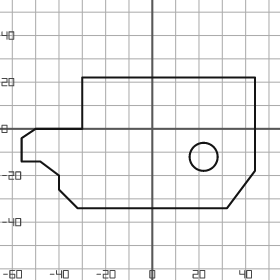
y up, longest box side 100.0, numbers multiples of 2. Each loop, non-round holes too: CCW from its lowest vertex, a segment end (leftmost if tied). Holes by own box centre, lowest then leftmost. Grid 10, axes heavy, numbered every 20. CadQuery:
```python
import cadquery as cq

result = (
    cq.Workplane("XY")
    .moveTo(-32.0, -34.0)
    .lineTo(32.0, -34.0)
    .lineTo(44.0, -18.0)
    .lineTo(44.0, 22.0)
    .lineTo(-30.0, 22.0)
    .lineTo(-30.0, 0.0)
    .lineTo(-50.0, 0.0)
    .lineTo(-56.0, -4.0)
    .lineTo(-56.0, -14.0)
    .lineTo(-48.0, -14.0)
    .lineTo(-40.0, -20.0)
    .lineTo(-40.0, -26.0)
    .close()
    .moveTo(22.0, -12.0)
    .circle(6.0)
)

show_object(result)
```